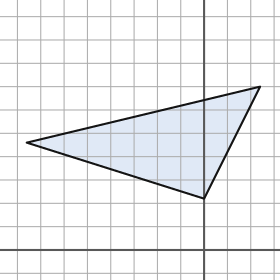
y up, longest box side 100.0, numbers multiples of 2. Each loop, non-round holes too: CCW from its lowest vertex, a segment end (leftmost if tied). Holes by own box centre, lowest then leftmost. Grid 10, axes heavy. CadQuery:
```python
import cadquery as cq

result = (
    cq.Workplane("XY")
    .moveTo(0.0, 22.0)
    .lineTo(24.0, 70.0)
    .lineTo(-76.0, 46.0)
    .close()
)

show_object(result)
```